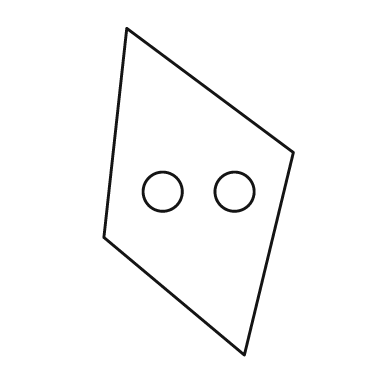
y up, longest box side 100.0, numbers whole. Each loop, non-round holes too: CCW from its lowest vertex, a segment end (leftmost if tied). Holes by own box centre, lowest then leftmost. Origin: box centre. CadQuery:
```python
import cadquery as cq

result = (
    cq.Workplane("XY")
    .moveTo(14.0, -50.0)
    .lineTo(29.0, 12.0)
    .lineTo(-22.0, 50.0)
    .lineTo(-29.0, -14.0)
    .close()
    .moveTo(-11.0, 0.0)
    .circle(6.0)
    .moveTo(11.0, 0.0)
    .circle(6.0)
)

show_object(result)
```